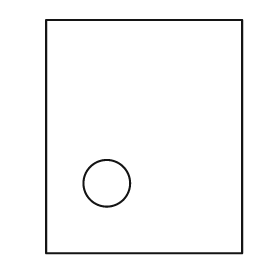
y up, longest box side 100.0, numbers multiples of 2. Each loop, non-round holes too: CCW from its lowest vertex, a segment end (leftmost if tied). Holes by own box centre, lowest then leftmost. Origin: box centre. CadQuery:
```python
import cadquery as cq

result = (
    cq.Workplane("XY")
    .moveTo(-42.0, -50.0)
    .lineTo(42.0, -50.0)
    .lineTo(42.0, 50.0)
    .lineTo(-42.0, 50.0)
    .close()
    .moveTo(-16.0, -20.0)
    .circle(10.0)
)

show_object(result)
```